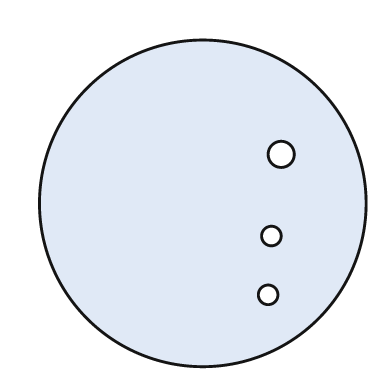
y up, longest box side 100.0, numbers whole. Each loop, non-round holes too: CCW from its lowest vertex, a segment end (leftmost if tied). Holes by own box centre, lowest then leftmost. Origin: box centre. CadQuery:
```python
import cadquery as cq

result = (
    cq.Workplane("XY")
    .moveTo(0.0, 0.0)
    .circle(50.0)
    .moveTo(20.0, -28.0)
    .circle(3.0)
    .moveTo(21.0, -10.0)
    .circle(3.0)
    .moveTo(24.0, 15.0)
    .circle(4.0)
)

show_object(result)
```